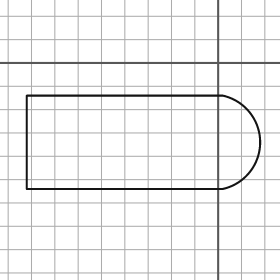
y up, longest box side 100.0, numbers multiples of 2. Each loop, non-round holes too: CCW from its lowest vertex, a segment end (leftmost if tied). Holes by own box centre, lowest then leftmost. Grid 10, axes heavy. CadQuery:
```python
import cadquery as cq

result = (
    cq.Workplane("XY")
    .moveTo(-82.0, -54.0)
    .lineTo(2.0, -54.0)
    .threePointArc((18.0, -34.0), (2.0, -14.0))
    .lineTo(-82.0, -14.0)
    .close()
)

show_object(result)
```